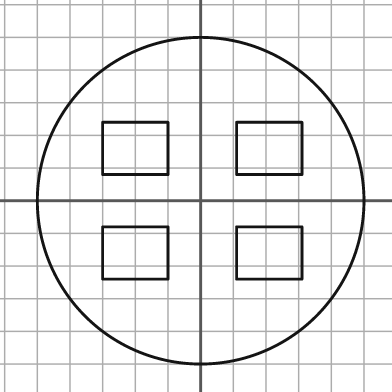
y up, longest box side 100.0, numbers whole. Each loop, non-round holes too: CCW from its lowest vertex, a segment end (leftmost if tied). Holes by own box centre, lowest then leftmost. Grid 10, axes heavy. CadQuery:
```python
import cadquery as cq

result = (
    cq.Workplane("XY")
    .moveTo(0.0, 0.0)
    .circle(50.0)
    .moveTo(-30.0, -24.0)
    .lineTo(-10.0, -24.0)
    .lineTo(-10.0, -8.0)
    .lineTo(-30.0, -8.0)
    .close()
    .moveTo(11.0, -24.0)
    .lineTo(31.0, -24.0)
    .lineTo(31.0, -8.0)
    .lineTo(11.0, -8.0)
    .close()
    .moveTo(-30.0, 8.0)
    .lineTo(-10.0, 8.0)
    .lineTo(-10.0, 24.0)
    .lineTo(-30.0, 24.0)
    .close()
    .moveTo(11.0, 8.0)
    .lineTo(31.0, 8.0)
    .lineTo(31.0, 24.0)
    .lineTo(11.0, 24.0)
    .close()
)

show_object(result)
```